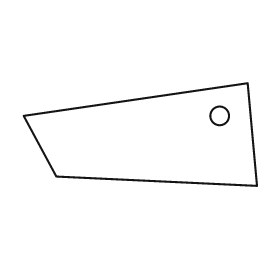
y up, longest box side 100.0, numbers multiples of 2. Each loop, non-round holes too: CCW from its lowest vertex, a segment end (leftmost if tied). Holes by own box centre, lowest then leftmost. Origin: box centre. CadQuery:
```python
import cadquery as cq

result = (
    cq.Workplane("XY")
    .moveTo(50.0, -22.0)
    .lineTo(46.0, 22.0)
    .lineTo(-50.0, 8.0)
    .lineTo(-36.0, -18.0)
    .close()
    .moveTo(34.0, 8.0)
    .circle(4.0)
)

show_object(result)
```